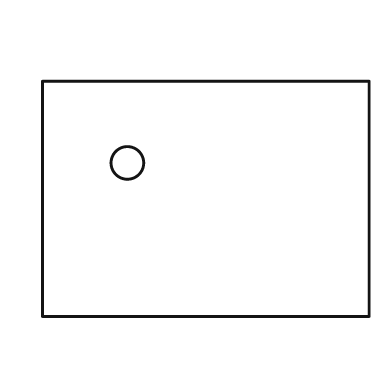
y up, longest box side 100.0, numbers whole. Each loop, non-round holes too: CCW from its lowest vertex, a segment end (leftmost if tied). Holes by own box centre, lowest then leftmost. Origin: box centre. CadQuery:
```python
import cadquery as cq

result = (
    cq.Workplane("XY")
    .moveTo(-50.0, -36.0)
    .lineTo(50.0, -36.0)
    .lineTo(50.0, 36.0)
    .lineTo(-50.0, 36.0)
    .close()
    .moveTo(-24.0, 11.0)
    .circle(5.0)
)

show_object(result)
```